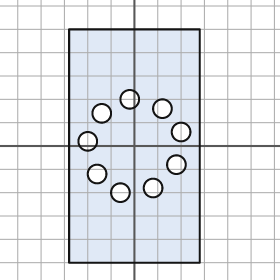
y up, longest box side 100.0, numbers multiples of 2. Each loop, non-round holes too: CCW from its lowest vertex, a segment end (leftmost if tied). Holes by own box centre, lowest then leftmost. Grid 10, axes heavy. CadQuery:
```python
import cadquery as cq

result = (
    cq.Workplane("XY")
    .moveTo(-28.0, -50.0)
    .lineTo(28.0, -50.0)
    .lineTo(28.0, 50.0)
    .lineTo(-28.0, 50.0)
    .close()
    .moveTo(-6.0, -20.0)
    .circle(4.0)
    .moveTo(8.0, -18.0)
    .circle(4.0)
    .moveTo(-16.0, -12.0)
    .circle(4.0)
    .moveTo(18.0, -8.0)
    .circle(4.0)
    .moveTo(-20.0, 2.0)
    .circle(4.0)
    .moveTo(20.0, 6.0)
    .circle(4.0)
    .moveTo(-14.0, 14.0)
    .circle(4.0)
    .moveTo(12.0, 16.0)
    .circle(4.0)
    .moveTo(-2.0, 20.0)
    .circle(4.0)
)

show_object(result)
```